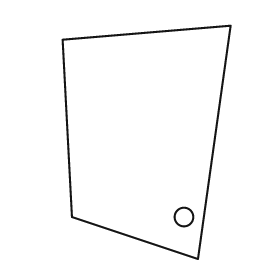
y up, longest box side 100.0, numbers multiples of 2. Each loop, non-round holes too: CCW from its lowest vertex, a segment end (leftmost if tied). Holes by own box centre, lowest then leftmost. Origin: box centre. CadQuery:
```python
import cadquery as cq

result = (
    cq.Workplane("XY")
    .moveTo(22.0, -50.0)
    .lineTo(36.0, 50.0)
    .lineTo(-36.0, 44.0)
    .lineTo(-32.0, -32.0)
    .close()
    .moveTo(16.0, -32.0)
    .circle(4.0)
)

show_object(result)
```